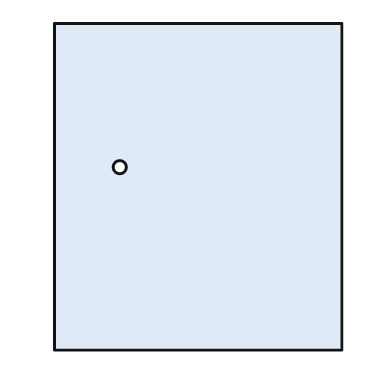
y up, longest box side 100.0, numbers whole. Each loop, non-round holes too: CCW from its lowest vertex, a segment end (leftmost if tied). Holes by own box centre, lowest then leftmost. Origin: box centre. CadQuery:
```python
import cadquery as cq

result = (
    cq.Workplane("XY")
    .moveTo(-44.0, -50.0)
    .lineTo(44.0, -50.0)
    .lineTo(44.0, 50.0)
    .lineTo(-44.0, 50.0)
    .close()
    .moveTo(-24.0, 6.0)
    .circle(2.0)
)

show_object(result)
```